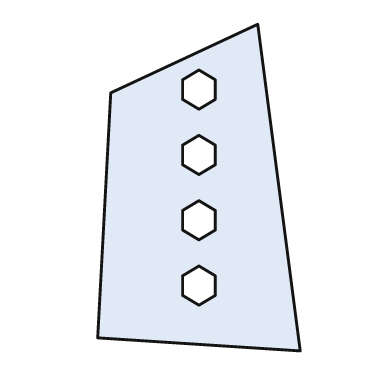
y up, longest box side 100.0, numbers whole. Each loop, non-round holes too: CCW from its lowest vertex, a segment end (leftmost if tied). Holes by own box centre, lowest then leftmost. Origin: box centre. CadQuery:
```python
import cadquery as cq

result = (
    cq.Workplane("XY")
    .moveTo(31.0, -50.0)
    .lineTo(18.0, 50.0)
    .lineTo(-27.0, 29.0)
    .lineTo(-31.0, -46.0)
    .close()
    .moveTo(0.0, -36.0)
    .lineTo(5.0, -33.0)
    .lineTo(5.0, -27.0)
    .lineTo(0.0, -24.0)
    .lineTo(-5.0, -27.0)
    .lineTo(-5.0, -33.0)
    .close()
    .moveTo(0.0, -16.0)
    .lineTo(5.0, -13.0)
    .lineTo(5.0, -7.0)
    .lineTo(0.0, -4.0)
    .lineTo(-5.0, -7.0)
    .lineTo(-5.0, -13.0)
    .close()
    .moveTo(0.0, 4.0)
    .lineTo(5.0, 7.0)
    .lineTo(5.0, 13.0)
    .lineTo(0.0, 16.0)
    .lineTo(-5.0, 13.0)
    .lineTo(-5.0, 7.0)
    .close()
    .moveTo(0.0, 24.0)
    .lineTo(5.0, 27.0)
    .lineTo(5.0, 33.0)
    .lineTo(0.0, 36.0)
    .lineTo(-5.0, 33.0)
    .lineTo(-5.0, 27.0)
    .close()
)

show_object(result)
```